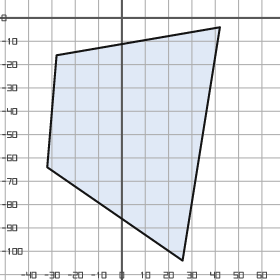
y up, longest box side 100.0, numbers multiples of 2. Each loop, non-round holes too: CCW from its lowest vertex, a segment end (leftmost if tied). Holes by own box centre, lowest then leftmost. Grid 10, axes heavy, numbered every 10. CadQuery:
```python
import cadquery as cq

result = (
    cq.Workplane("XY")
    .moveTo(26.0, -104.0)
    .lineTo(42.0, -4.0)
    .lineTo(-28.0, -16.0)
    .lineTo(-32.0, -64.0)
    .close()
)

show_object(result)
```